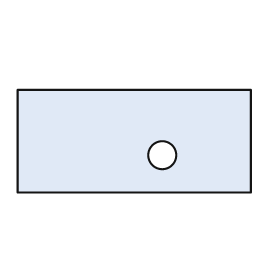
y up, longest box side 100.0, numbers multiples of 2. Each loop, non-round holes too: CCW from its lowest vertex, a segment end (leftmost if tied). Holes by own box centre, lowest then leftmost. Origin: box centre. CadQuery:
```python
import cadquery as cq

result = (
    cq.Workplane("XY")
    .moveTo(-50.0, -22.0)
    .lineTo(50.0, -22.0)
    .lineTo(50.0, 22.0)
    .lineTo(-50.0, 22.0)
    .close()
    .moveTo(12.0, -6.0)
    .circle(6.0)
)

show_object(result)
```